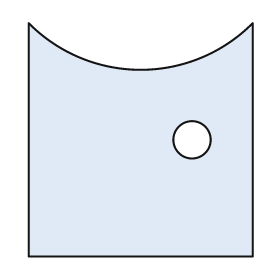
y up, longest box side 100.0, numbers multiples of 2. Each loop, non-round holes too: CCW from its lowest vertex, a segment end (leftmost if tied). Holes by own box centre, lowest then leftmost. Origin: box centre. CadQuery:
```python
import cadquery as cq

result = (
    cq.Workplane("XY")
    .moveTo(-48.0, -50.0)
    .lineTo(48.0, -50.0)
    .lineTo(48.0, 50.0)
    .threePointArc((0.0, 30.0), (-48.0, 50.0))
    .close()
    .moveTo(22.0, 0.0)
    .circle(8.0)
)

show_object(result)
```